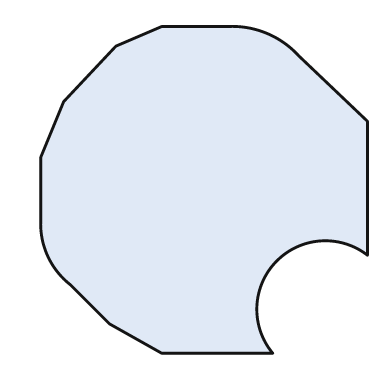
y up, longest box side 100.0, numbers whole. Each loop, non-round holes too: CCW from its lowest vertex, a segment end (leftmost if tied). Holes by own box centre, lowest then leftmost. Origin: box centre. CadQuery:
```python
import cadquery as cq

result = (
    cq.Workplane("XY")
    .moveTo(-13.0, -50.0)
    .lineTo(21.0, -50.0)
    .threePointArc((22.0, -22.0), (50.0, -20.0))
    .lineTo(50.0, 21.0)
    .lineTo(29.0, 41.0)
    .threePointArc((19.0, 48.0), (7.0, 50.0))
    .lineTo(-13.0, 50.0)
    .lineTo(-27.0, 44.0)
    .lineTo(-43.0, 27.0)
    .lineTo(-50.0, 10.0)
    .lineTo(-50.0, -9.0)
    .threePointArc((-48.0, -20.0), (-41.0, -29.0))
    .lineTo(-29.0, -41.0)
    .close()
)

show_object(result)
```